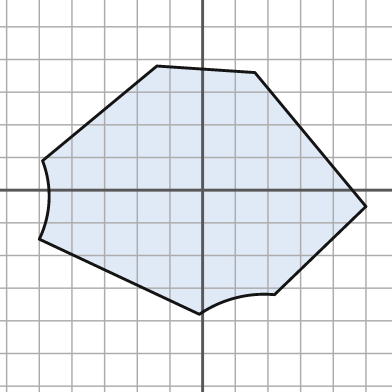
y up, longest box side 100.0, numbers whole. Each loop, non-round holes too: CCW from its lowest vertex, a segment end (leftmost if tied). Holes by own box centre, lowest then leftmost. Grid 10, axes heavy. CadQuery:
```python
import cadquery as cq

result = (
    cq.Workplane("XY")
    .moveTo(-1.0, -38.0)
    .threePointArc((10.0, -33.0), (22.0, -32.0))
    .lineTo(50.0, -5.0)
    .lineTo(16.0, 36.0)
    .lineTo(-14.0, 38.0)
    .lineTo(-49.0, 9.0)
    .threePointArc((-47.0, -3.0), (-50.0, -15.0))
    .close()
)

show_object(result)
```